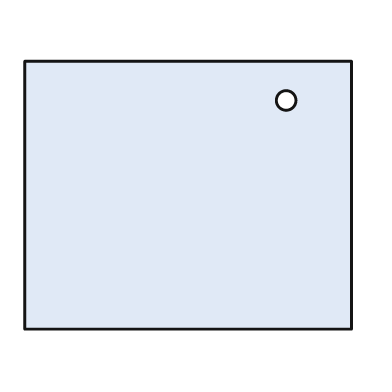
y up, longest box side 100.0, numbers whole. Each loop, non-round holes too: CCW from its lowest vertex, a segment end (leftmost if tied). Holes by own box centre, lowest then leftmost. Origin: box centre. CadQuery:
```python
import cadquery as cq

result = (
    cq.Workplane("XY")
    .moveTo(-50.0, -41.0)
    .lineTo(50.0, -41.0)
    .lineTo(50.0, 41.0)
    .lineTo(-50.0, 41.0)
    .close()
    .moveTo(30.0, 29.0)
    .circle(3.0)
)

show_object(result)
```